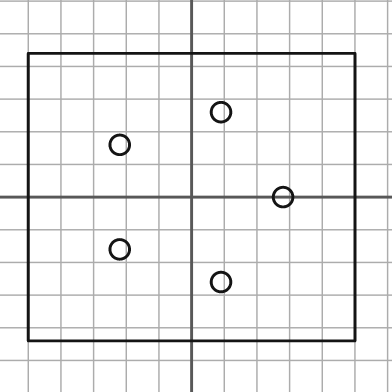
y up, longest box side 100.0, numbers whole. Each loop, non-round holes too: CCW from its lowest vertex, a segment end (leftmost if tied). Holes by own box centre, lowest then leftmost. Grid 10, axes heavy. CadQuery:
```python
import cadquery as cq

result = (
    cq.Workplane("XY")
    .moveTo(-50.0, -44.0)
    .lineTo(50.0, -44.0)
    .lineTo(50.0, 44.0)
    .lineTo(-50.0, 44.0)
    .close()
    .moveTo(9.0, -26.0)
    .circle(3.0)
    .moveTo(-22.0, -16.0)
    .circle(3.0)
    .moveTo(28.0, 0.0)
    .circle(3.0)
    .moveTo(-22.0, 16.0)
    .circle(3.0)
    .moveTo(9.0, 26.0)
    .circle(3.0)
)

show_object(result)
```